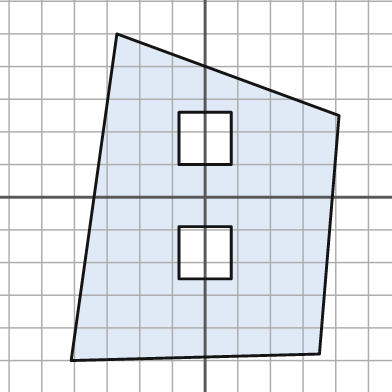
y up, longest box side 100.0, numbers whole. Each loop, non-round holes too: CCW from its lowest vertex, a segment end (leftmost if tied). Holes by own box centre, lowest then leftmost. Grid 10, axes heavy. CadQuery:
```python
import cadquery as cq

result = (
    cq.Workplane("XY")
    .moveTo(-41.0, -50.0)
    .lineTo(35.0, -48.0)
    .lineTo(41.0, 25.0)
    .lineTo(-27.0, 50.0)
    .close()
    .moveTo(-8.0, -25.0)
    .lineTo(8.0, -25.0)
    .lineTo(8.0, -9.0)
    .lineTo(-8.0, -9.0)
    .close()
    .moveTo(-8.0, 10.0)
    .lineTo(8.0, 10.0)
    .lineTo(8.0, 26.0)
    .lineTo(-8.0, 26.0)
    .close()
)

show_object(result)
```